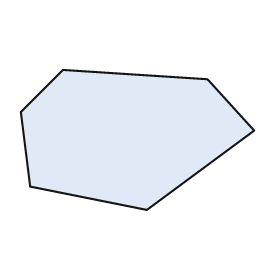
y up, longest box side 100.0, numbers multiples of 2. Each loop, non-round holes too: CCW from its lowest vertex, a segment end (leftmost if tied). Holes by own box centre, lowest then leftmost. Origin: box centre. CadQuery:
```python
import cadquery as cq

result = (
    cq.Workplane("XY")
    .moveTo(4.0, -30.0)
    .lineTo(50.0, 4.0)
    .lineTo(30.0, 26.0)
    .lineTo(-32.0, 30.0)
    .lineTo(-50.0, 12.0)
    .lineTo(-46.0, -20.0)
    .close()
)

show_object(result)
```